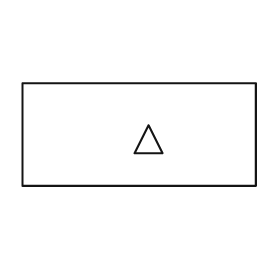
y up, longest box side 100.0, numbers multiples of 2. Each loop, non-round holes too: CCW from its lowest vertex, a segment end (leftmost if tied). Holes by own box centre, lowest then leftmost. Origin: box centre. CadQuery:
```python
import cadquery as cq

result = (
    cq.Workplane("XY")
    .moveTo(-50.0, -22.0)
    .lineTo(50.0, -22.0)
    .lineTo(50.0, 22.0)
    .lineTo(-50.0, 22.0)
    .close()
    .moveTo(-2.0, -8.0)
    .lineTo(10.0, -8.0)
    .lineTo(4.0, 4.0)
    .close()
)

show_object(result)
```